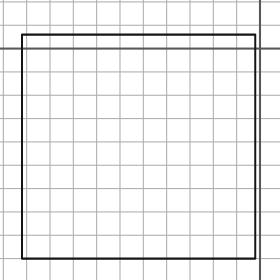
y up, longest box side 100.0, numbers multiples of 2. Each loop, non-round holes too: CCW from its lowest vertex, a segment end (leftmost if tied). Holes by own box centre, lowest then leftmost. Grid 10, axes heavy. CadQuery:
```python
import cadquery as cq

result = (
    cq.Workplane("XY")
    .moveTo(-102.0, -90.0)
    .lineTo(-2.0, -90.0)
    .lineTo(-2.0, 6.0)
    .lineTo(-102.0, 6.0)
    .close()
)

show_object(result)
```